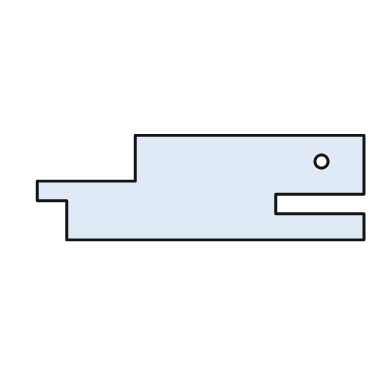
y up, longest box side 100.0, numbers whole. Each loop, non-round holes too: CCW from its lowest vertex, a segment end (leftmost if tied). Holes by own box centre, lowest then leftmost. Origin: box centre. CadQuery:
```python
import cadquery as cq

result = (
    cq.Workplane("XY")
    .moveTo(-41.0, -16.0)
    .lineTo(50.0, -16.0)
    .lineTo(50.0, -8.0)
    .lineTo(23.0, -8.0)
    .lineTo(23.0, -2.0)
    .lineTo(50.0, -2.0)
    .lineTo(50.0, 16.0)
    .lineTo(-20.0, 16.0)
    .lineTo(-20.0, 2.0)
    .lineTo(-50.0, 2.0)
    .lineTo(-50.0, -4.0)
    .lineTo(-41.0, -4.0)
    .close()
    .moveTo(37.0, 8.0)
    .circle(2.0)
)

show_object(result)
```